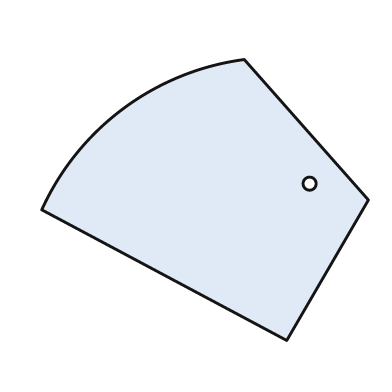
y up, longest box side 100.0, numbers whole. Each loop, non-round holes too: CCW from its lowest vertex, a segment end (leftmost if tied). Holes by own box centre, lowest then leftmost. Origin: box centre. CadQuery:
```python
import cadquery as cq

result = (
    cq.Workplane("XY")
    .moveTo(25.0, -43.0)
    .lineTo(50.0, 0.0)
    .lineTo(12.0, 43.0)
    .threePointArc((-25.0, 28.0), (-50.0, -3.0))
    .close()
    .moveTo(32.0, 5.0)
    .circle(2.0)
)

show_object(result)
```